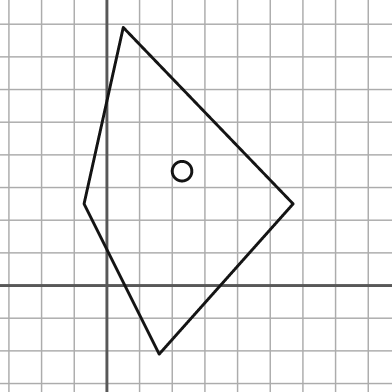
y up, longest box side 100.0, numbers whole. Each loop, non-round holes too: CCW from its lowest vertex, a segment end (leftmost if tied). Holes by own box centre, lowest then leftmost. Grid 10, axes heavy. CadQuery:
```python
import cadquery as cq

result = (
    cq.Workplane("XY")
    .moveTo(16.0, -21.0)
    .lineTo(57.0, 25.0)
    .lineTo(5.0, 79.0)
    .lineTo(-7.0, 25.0)
    .close()
    .moveTo(23.0, 35.0)
    .circle(3.0)
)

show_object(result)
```